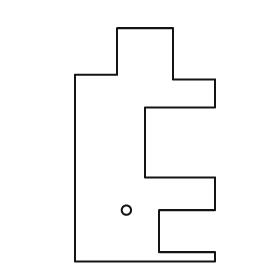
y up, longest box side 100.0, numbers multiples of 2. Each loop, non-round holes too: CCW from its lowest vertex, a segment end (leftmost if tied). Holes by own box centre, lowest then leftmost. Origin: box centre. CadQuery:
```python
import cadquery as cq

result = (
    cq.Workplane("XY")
    .moveTo(-30.0, -50.0)
    .lineTo(30.0, -50.0)
    .lineTo(30.0, -46.0)
    .lineTo(6.0, -46.0)
    .lineTo(6.0, -28.0)
    .lineTo(30.0, -28.0)
    .lineTo(30.0, -14.0)
    .lineTo(0.0, -14.0)
    .lineTo(0.0, 16.0)
    .lineTo(30.0, 16.0)
    .lineTo(30.0, 28.0)
    .lineTo(12.0, 28.0)
    .lineTo(12.0, 50.0)
    .lineTo(-12.0, 50.0)
    .lineTo(-12.0, 30.0)
    .lineTo(-30.0, 30.0)
    .close()
    .moveTo(-8.0, -28.0)
    .circle(2.0)
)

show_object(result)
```